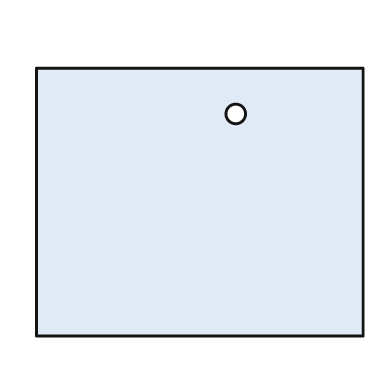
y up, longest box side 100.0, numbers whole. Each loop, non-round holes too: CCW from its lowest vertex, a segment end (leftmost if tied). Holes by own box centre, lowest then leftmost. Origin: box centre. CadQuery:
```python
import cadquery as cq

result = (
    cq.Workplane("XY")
    .moveTo(-50.0, -41.0)
    .lineTo(50.0, -41.0)
    .lineTo(50.0, 41.0)
    .lineTo(-50.0, 41.0)
    .close()
    .moveTo(11.0, 27.0)
    .circle(3.0)
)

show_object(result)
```